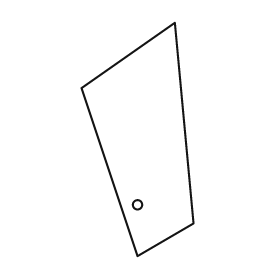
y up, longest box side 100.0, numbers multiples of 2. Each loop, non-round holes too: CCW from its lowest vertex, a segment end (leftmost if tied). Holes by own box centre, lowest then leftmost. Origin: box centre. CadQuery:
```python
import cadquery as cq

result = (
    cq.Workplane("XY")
    .moveTo(0.0, -50.0)
    .lineTo(24.0, -36.0)
    .lineTo(16.0, 50.0)
    .lineTo(-24.0, 22.0)
    .close()
    .moveTo(0.0, -28.0)
    .circle(2.0)
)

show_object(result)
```